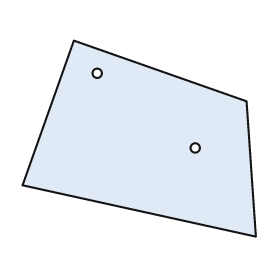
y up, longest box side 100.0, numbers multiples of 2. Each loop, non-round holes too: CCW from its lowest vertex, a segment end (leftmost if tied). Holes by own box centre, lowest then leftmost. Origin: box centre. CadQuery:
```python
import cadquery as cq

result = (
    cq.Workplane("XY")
    .moveTo(50.0, -42.0)
    .lineTo(46.0, 16.0)
    .lineTo(-28.0, 42.0)
    .lineTo(-50.0, -20.0)
    .close()
    .moveTo(24.0, -4.0)
    .circle(2.0)
    .moveTo(-18.0, 28.0)
    .circle(2.0)
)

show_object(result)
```